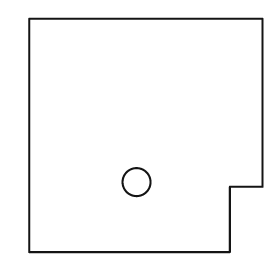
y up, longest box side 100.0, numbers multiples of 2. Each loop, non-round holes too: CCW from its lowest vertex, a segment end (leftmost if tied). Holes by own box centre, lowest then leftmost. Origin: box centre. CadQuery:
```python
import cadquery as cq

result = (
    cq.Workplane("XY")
    .moveTo(-50.0, -50.0)
    .lineTo(36.0, -50.0)
    .lineTo(36.0, -22.0)
    .lineTo(50.0, -22.0)
    .lineTo(50.0, 50.0)
    .lineTo(-50.0, 50.0)
    .close()
    .moveTo(-4.0, -20.0)
    .circle(6.0)
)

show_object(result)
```